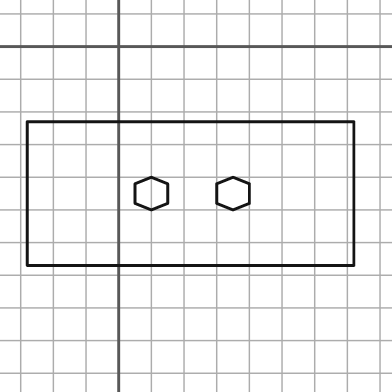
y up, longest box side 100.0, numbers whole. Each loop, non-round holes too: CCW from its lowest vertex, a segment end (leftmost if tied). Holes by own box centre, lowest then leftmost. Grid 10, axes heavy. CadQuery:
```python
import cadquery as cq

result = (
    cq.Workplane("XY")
    .moveTo(-28.0, -67.0)
    .lineTo(72.0, -67.0)
    .lineTo(72.0, -23.0)
    .lineTo(-28.0, -23.0)
    .close()
    .moveTo(10.0, -50.0)
    .lineTo(15.0, -48.0)
    .lineTo(15.0, -42.0)
    .lineTo(10.0, -40.0)
    .lineTo(5.0, -42.0)
    .lineTo(5.0, -48.0)
    .close()
    .moveTo(35.0, -50.0)
    .lineTo(40.0, -48.0)
    .lineTo(40.0, -42.0)
    .lineTo(35.0, -40.0)
    .lineTo(30.0, -42.0)
    .lineTo(30.0, -48.0)
    .close()
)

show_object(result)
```